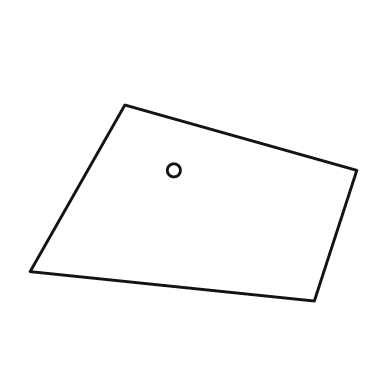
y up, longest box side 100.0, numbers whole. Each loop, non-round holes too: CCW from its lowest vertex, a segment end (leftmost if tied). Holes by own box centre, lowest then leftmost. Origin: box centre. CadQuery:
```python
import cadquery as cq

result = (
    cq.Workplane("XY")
    .moveTo(37.0, -30.0)
    .lineTo(50.0, 10.0)
    .lineTo(-21.0, 30.0)
    .lineTo(-50.0, -21.0)
    .close()
    .moveTo(-6.0, 10.0)
    .circle(2.0)
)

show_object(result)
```